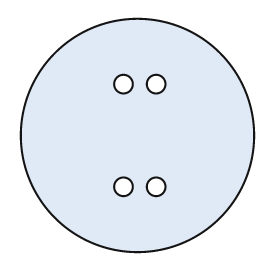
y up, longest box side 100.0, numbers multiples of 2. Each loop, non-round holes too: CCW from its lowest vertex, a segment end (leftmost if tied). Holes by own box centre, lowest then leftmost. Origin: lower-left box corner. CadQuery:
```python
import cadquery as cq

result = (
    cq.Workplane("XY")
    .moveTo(50.0, 50.0)
    .circle(50.0)
    .moveTo(44.0, 28.0)
    .circle(4.0)
    .moveTo(58.0, 28.0)
    .circle(4.0)
    .moveTo(44.0, 72.0)
    .circle(4.0)
    .moveTo(58.0, 72.0)
    .circle(4.0)
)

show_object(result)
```